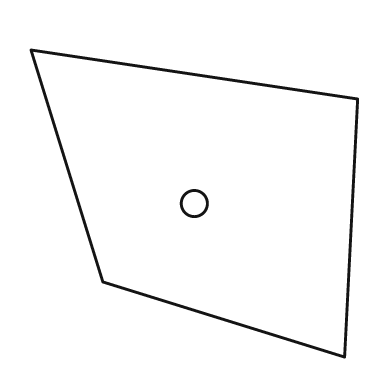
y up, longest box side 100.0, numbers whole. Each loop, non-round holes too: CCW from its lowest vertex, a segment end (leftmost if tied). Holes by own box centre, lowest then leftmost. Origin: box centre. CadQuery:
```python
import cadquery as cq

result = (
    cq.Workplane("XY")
    .moveTo(46.0, -47.0)
    .lineTo(50.0, 32.0)
    .lineTo(-50.0, 47.0)
    .lineTo(-28.0, -24.0)
    .close()
    .moveTo(0.0, 0.0)
    .circle(4.0)
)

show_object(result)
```